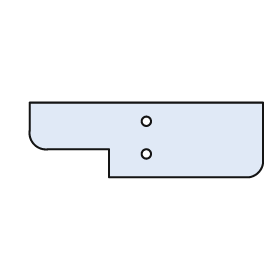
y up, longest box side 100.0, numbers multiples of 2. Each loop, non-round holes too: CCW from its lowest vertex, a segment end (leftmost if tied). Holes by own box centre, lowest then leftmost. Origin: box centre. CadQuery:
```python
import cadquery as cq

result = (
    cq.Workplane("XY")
    .moveTo(-16.0, -16.0)
    .lineTo(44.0, -16.0)
    .threePointArc((48.0, -14.0), (50.0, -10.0))
    .lineTo(50.0, 16.0)
    .lineTo(-50.0, 16.0)
    .lineTo(-50.0, 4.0)
    .threePointArc((-48.0, -2.0), (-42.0, -4.0))
    .lineTo(-16.0, -4.0)
    .close()
    .moveTo(0.0, -6.0)
    .circle(2.0)
    .moveTo(0.0, 8.0)
    .circle(2.0)
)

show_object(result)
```